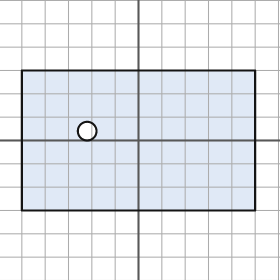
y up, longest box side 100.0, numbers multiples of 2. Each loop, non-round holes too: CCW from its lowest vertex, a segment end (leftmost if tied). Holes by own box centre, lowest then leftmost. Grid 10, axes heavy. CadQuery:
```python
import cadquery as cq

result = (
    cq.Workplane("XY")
    .moveTo(-50.0, -30.0)
    .lineTo(50.0, -30.0)
    .lineTo(50.0, 30.0)
    .lineTo(-50.0, 30.0)
    .close()
    .moveTo(-22.0, 4.0)
    .circle(4.0)
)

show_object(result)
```